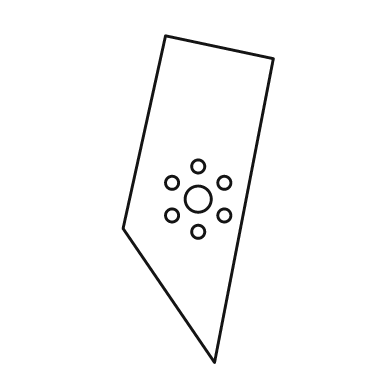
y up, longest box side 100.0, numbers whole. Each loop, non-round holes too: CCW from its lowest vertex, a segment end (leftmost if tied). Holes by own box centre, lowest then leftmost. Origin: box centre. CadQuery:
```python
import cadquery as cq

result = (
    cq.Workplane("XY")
    .moveTo(5.0, -50.0)
    .lineTo(23.0, 43.0)
    .lineTo(-10.0, 50.0)
    .lineTo(-23.0, -9.0)
    .close()
    .moveTo(0.0, -10.0)
    .circle(2.0)
    .moveTo(-8.0, -5.0)
    .circle(2.0)
    .moveTo(8.0, -5.0)
    .circle(2.0)
    .moveTo(0.0, 0.0)
    .circle(4.0)
    .moveTo(-8.0, 5.0)
    .circle(2.0)
    .moveTo(8.0, 5.0)
    .circle(2.0)
    .moveTo(0.0, 10.0)
    .circle(2.0)
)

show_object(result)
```